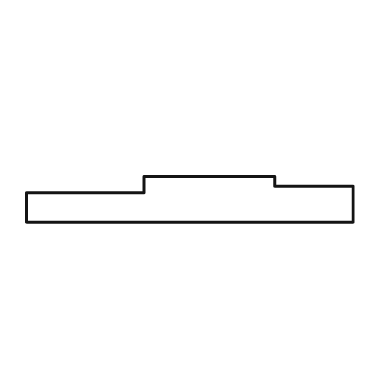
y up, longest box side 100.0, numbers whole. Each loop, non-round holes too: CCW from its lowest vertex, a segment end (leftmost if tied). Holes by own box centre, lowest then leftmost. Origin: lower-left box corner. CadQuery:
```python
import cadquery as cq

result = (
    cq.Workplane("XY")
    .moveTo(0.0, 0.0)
    .lineTo(100.0, 0.0)
    .lineTo(100.0, 11.0)
    .lineTo(76.0, 11.0)
    .lineTo(76.0, 14.0)
    .lineTo(36.0, 14.0)
    .lineTo(36.0, 9.0)
    .lineTo(0.0, 9.0)
    .close()
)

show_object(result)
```